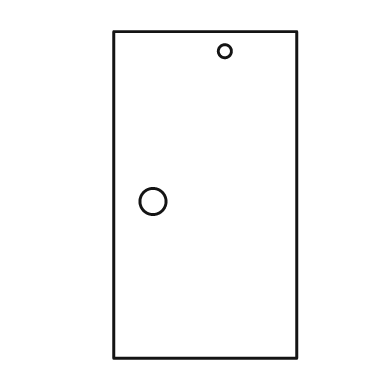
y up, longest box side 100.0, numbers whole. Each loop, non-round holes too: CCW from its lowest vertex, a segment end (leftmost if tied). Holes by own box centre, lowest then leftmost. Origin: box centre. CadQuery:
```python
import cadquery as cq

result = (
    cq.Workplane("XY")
    .moveTo(-28.0, -50.0)
    .lineTo(28.0, -50.0)
    .lineTo(28.0, 50.0)
    .lineTo(-28.0, 50.0)
    .close()
    .moveTo(-16.0, -2.0)
    .circle(4.0)
    .moveTo(6.0, 44.0)
    .circle(2.0)
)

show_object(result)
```